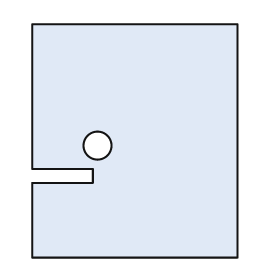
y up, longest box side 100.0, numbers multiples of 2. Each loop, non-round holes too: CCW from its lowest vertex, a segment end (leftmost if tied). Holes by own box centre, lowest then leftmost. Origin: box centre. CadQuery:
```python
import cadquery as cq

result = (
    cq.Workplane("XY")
    .moveTo(-44.0, -50.0)
    .lineTo(44.0, -50.0)
    .lineTo(44.0, 50.0)
    .lineTo(-44.0, 50.0)
    .lineTo(-44.0, -12.0)
    .lineTo(-18.0, -12.0)
    .lineTo(-18.0, -18.0)
    .lineTo(-44.0, -18.0)
    .close()
    .moveTo(-16.0, -2.0)
    .circle(6.0)
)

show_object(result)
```